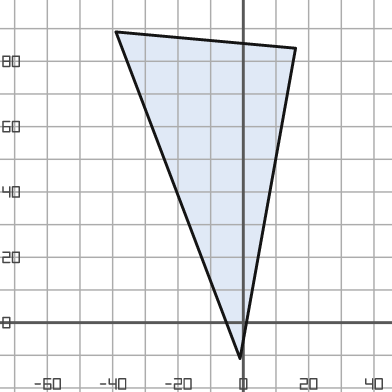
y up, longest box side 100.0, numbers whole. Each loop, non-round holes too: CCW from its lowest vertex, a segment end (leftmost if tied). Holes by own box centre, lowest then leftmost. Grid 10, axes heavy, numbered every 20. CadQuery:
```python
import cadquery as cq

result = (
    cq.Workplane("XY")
    .moveTo(-1.0, -11.0)
    .lineTo(16.0, 84.0)
    .lineTo(-39.0, 89.0)
    .close()
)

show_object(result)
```